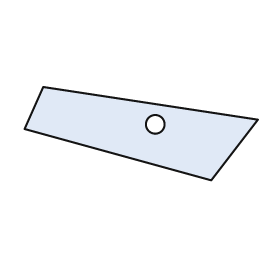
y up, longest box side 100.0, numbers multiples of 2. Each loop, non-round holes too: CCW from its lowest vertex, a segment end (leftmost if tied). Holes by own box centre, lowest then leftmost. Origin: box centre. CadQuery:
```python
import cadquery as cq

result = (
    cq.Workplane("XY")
    .moveTo(30.0, -20.0)
    .lineTo(50.0, 6.0)
    .lineTo(-42.0, 20.0)
    .lineTo(-50.0, 2.0)
    .close()
    .moveTo(6.0, 4.0)
    .circle(4.0)
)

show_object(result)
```